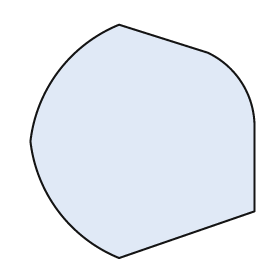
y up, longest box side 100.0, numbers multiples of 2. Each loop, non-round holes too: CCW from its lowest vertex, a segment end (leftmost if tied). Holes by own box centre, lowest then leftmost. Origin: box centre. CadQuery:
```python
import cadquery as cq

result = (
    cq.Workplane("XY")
    .moveTo(-10.0, -50.0)
    .lineTo(48.0, -30.0)
    .lineTo(48.0, 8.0)
    .threePointArc((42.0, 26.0), (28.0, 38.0))
    .lineTo(-10.0, 50.0)
    .threePointArc((-36.0, 30.0), (-48.0, 0.0))
    .threePointArc((-36.0, -30.0), (-10.0, -50.0))
    .close()
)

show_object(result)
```